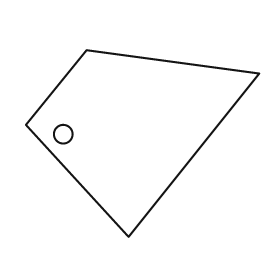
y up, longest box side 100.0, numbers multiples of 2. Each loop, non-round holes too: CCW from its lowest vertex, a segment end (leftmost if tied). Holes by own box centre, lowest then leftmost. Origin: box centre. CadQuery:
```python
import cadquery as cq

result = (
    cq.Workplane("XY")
    .moveTo(-6.0, -40.0)
    .lineTo(50.0, 30.0)
    .lineTo(-24.0, 40.0)
    .lineTo(-50.0, 8.0)
    .close()
    .moveTo(-34.0, 4.0)
    .circle(4.0)
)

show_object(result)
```